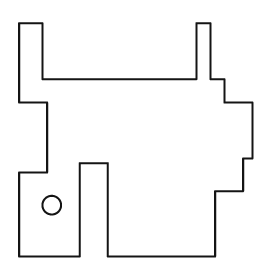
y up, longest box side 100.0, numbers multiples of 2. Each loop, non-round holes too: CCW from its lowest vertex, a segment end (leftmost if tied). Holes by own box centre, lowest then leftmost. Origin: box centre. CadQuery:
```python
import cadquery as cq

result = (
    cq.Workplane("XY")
    .moveTo(-50.0, -50.0)
    .lineTo(-24.0, -50.0)
    .lineTo(-24.0, -10.0)
    .lineTo(-12.0, -10.0)
    .lineTo(-12.0, -50.0)
    .lineTo(34.0, -50.0)
    .lineTo(34.0, -22.0)
    .lineTo(46.0, -22.0)
    .lineTo(46.0, -8.0)
    .lineTo(50.0, -8.0)
    .lineTo(50.0, 16.0)
    .lineTo(38.0, 16.0)
    .lineTo(38.0, 26.0)
    .lineTo(32.0, 26.0)
    .lineTo(32.0, 50.0)
    .lineTo(26.0, 50.0)
    .lineTo(26.0, 26.0)
    .lineTo(-40.0, 26.0)
    .lineTo(-40.0, 50.0)
    .lineTo(-50.0, 50.0)
    .lineTo(-50.0, 16.0)
    .lineTo(-38.0, 16.0)
    .lineTo(-38.0, -14.0)
    .lineTo(-50.0, -14.0)
    .close()
    .moveTo(-36.0, -28.0)
    .circle(4.0)
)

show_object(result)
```